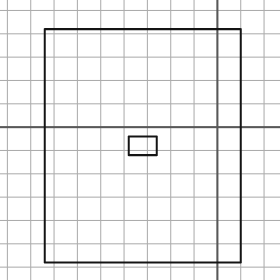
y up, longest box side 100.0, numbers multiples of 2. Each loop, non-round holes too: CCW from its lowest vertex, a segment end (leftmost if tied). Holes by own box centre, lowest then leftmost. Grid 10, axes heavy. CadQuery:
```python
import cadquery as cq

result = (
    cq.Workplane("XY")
    .moveTo(-74.0, -58.0)
    .lineTo(10.0, -58.0)
    .lineTo(10.0, 42.0)
    .lineTo(-74.0, 42.0)
    .close()
    .moveTo(-38.0, -12.0)
    .lineTo(-26.0, -12.0)
    .lineTo(-26.0, -4.0)
    .lineTo(-38.0, -4.0)
    .close()
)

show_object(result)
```